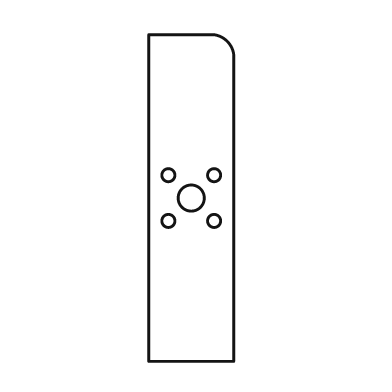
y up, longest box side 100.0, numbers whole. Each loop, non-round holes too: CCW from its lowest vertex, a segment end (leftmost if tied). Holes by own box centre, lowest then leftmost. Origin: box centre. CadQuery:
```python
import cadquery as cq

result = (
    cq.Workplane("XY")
    .moveTo(-13.0, -50.0)
    .lineTo(13.0, -50.0)
    .lineTo(13.0, 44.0)
    .threePointArc((11.0, 48.0), (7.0, 50.0))
    .lineTo(-13.0, 50.0)
    .close()
    .moveTo(-7.0, -7.0)
    .circle(2.0)
    .moveTo(7.0, -7.0)
    .circle(2.0)
    .moveTo(0.0, 0.0)
    .circle(4.0)
    .moveTo(-7.0, 7.0)
    .circle(2.0)
    .moveTo(7.0, 7.0)
    .circle(2.0)
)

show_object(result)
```